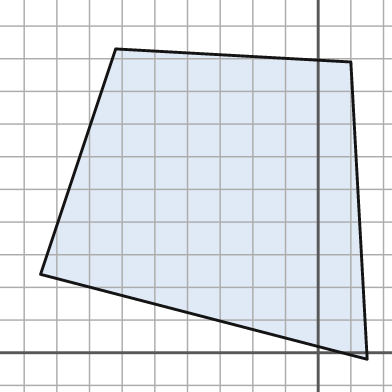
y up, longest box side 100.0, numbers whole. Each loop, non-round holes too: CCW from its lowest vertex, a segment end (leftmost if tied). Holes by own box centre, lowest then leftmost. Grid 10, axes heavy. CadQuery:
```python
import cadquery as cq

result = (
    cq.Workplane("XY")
    .moveTo(15.0, -2.0)
    .lineTo(10.0, 89.0)
    .lineTo(-62.0, 93.0)
    .lineTo(-85.0, 24.0)
    .close()
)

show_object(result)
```